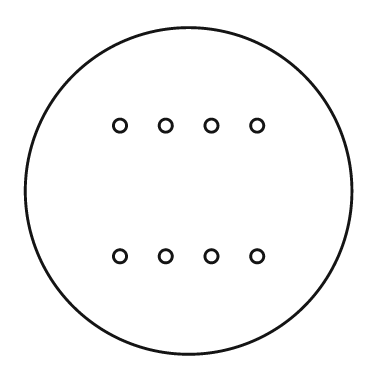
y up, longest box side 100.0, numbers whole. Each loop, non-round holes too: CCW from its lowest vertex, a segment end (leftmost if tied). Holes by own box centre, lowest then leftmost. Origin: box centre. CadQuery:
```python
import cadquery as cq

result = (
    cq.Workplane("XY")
    .moveTo(0.0, 0.0)
    .circle(50.0)
    .moveTo(-21.0, -20.0)
    .circle(2.0)
    .moveTo(-7.0, -20.0)
    .circle(2.0)
    .moveTo(7.0, -20.0)
    .circle(2.0)
    .moveTo(21.0, -20.0)
    .circle(2.0)
    .moveTo(-21.0, 20.0)
    .circle(2.0)
    .moveTo(-7.0, 20.0)
    .circle(2.0)
    .moveTo(7.0, 20.0)
    .circle(2.0)
    .moveTo(21.0, 20.0)
    .circle(2.0)
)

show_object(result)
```